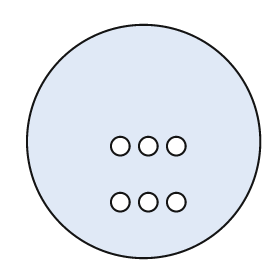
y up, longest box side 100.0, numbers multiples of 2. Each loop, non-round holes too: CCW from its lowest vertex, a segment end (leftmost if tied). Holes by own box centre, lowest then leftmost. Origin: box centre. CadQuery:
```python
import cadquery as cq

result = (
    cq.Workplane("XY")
    .moveTo(0.0, 0.0)
    .circle(50.0)
    .moveTo(-10.0, -26.0)
    .circle(4.0)
    .moveTo(2.0, -26.0)
    .circle(4.0)
    .moveTo(14.0, -26.0)
    .circle(4.0)
    .moveTo(-10.0, -2.0)
    .circle(4.0)
    .moveTo(2.0, -2.0)
    .circle(4.0)
    .moveTo(14.0, -2.0)
    .circle(4.0)
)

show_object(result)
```